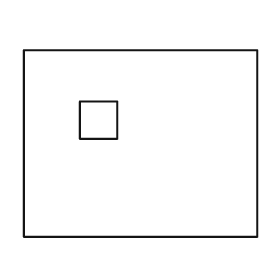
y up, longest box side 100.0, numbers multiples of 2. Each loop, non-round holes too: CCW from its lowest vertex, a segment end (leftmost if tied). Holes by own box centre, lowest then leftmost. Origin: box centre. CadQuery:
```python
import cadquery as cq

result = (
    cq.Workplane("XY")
    .moveTo(-50.0, -40.0)
    .lineTo(50.0, -40.0)
    .lineTo(50.0, 40.0)
    .lineTo(-50.0, 40.0)
    .close()
    .moveTo(-26.0, 2.0)
    .lineTo(-10.0, 2.0)
    .lineTo(-10.0, 18.0)
    .lineTo(-26.0, 18.0)
    .close()
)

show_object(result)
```